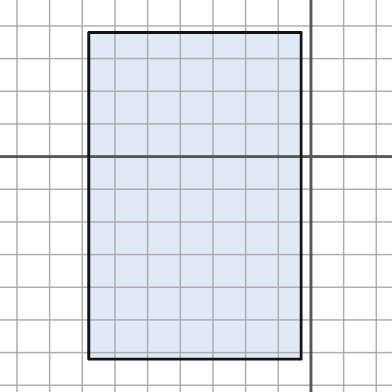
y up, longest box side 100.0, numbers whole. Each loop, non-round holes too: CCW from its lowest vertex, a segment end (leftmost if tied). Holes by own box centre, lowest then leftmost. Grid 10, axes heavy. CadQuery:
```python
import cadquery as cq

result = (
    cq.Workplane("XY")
    .moveTo(-68.0, -62.0)
    .lineTo(-3.0, -62.0)
    .lineTo(-3.0, 38.0)
    .lineTo(-68.0, 38.0)
    .close()
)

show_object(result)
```